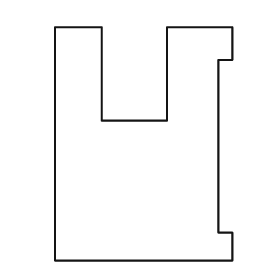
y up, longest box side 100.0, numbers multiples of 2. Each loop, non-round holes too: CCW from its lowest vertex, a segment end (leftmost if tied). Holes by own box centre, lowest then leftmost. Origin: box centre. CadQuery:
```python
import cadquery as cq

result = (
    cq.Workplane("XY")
    .moveTo(-38.0, -50.0)
    .lineTo(38.0, -50.0)
    .lineTo(38.0, -38.0)
    .lineTo(32.0, -38.0)
    .lineTo(32.0, 36.0)
    .lineTo(38.0, 36.0)
    .lineTo(38.0, 50.0)
    .lineTo(10.0, 50.0)
    .lineTo(10.0, 10.0)
    .lineTo(-18.0, 10.0)
    .lineTo(-18.0, 50.0)
    .lineTo(-38.0, 50.0)
    .close()
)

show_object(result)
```